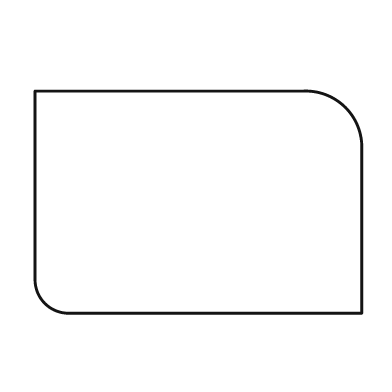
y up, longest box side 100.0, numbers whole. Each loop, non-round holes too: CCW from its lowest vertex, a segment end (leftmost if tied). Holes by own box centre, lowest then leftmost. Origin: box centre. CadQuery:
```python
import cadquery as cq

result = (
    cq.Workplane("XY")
    .moveTo(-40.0, -34.0)
    .lineTo(50.0, -34.0)
    .lineTo(50.0, 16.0)
    .threePointArc((45.0, 29.0), (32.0, 34.0))
    .lineTo(-50.0, 34.0)
    .lineTo(-50.0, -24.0)
    .threePointArc((-47.0, -31.0), (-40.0, -34.0))
    .close()
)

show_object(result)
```